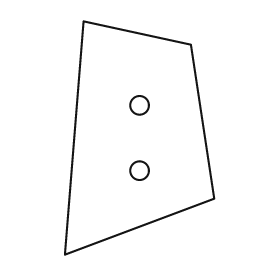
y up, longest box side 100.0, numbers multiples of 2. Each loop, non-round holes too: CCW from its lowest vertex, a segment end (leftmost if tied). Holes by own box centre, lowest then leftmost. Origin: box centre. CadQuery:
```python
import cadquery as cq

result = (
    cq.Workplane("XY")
    .moveTo(-32.0, -50.0)
    .lineTo(32.0, -26.0)
    .lineTo(22.0, 40.0)
    .lineTo(-24.0, 50.0)
    .close()
    .moveTo(0.0, -14.0)
    .circle(4.0)
    .moveTo(0.0, 14.0)
    .circle(4.0)
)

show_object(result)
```